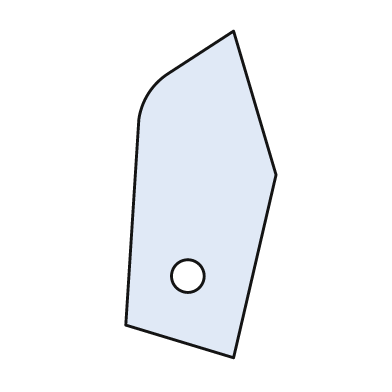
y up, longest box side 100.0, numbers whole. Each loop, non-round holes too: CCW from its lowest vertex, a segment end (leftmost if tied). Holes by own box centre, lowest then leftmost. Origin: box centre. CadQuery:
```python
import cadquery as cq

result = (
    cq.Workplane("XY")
    .moveTo(10.0, -50.0)
    .lineTo(23.0, 6.0)
    .lineTo(10.0, 50.0)
    .lineTo(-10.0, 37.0)
    .threePointArc((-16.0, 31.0), (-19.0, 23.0))
    .lineTo(-23.0, -40.0)
    .close()
    .moveTo(-4.0, -25.0)
    .circle(5.0)
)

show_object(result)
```